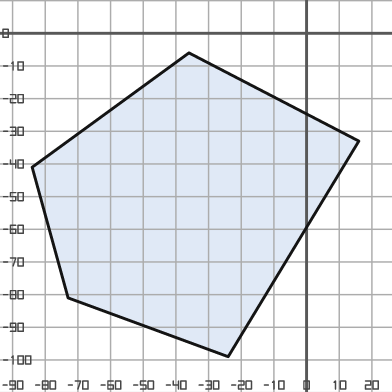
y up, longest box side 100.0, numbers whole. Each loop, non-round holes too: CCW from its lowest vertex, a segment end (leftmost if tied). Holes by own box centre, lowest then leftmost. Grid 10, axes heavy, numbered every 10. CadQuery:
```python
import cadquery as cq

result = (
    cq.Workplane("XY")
    .moveTo(-24.0, -99.0)
    .lineTo(16.0, -33.0)
    .lineTo(-36.0, -6.0)
    .lineTo(-84.0, -41.0)
    .lineTo(-73.0, -81.0)
    .close()
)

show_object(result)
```